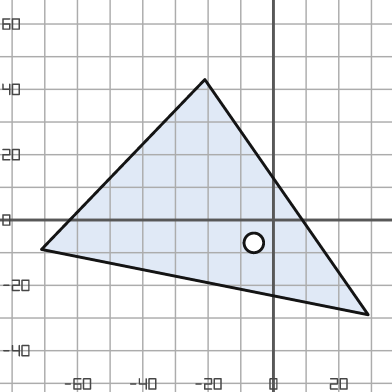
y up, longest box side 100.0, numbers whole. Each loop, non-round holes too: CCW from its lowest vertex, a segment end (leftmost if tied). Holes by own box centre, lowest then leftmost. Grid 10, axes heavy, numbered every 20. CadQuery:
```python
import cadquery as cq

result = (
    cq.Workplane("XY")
    .moveTo(29.0, -29.0)
    .lineTo(-21.0, 43.0)
    .lineTo(-71.0, -9.0)
    .close()
    .moveTo(-6.0, -7.0)
    .circle(3.0)
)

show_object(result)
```